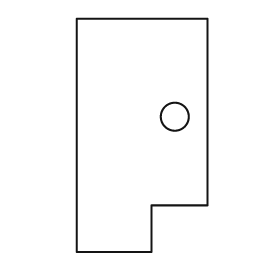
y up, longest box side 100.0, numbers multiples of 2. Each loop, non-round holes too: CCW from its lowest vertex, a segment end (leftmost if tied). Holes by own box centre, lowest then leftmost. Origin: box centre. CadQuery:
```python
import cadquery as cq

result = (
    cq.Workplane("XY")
    .moveTo(-28.0, -50.0)
    .lineTo(4.0, -50.0)
    .lineTo(4.0, -30.0)
    .lineTo(28.0, -30.0)
    .lineTo(28.0, 50.0)
    .lineTo(-28.0, 50.0)
    .close()
    .moveTo(14.0, 8.0)
    .circle(6.0)
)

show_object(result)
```